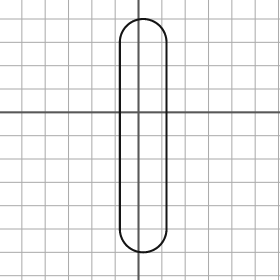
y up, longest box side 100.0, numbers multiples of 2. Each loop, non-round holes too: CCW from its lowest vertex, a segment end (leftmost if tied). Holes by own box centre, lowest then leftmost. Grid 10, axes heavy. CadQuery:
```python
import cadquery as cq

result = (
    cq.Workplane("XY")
    .moveTo(-8.0, -50.0)
    .threePointArc((2.0, -60.0), (12.0, -50.0))
    .lineTo(12.0, 30.0)
    .threePointArc((2.0, 40.0), (-8.0, 30.0))
    .close()
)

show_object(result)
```